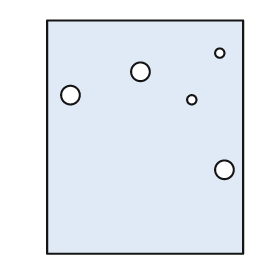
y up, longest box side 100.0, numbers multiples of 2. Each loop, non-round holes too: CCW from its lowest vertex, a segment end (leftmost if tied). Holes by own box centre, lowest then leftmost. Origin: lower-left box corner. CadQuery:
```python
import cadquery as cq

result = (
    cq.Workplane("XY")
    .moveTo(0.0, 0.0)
    .lineTo(84.0, 0.0)
    .lineTo(84.0, 100.0)
    .lineTo(0.0, 100.0)
    .close()
    .moveTo(76.0, 36.0)
    .circle(4.0)
    .moveTo(62.0, 66.0)
    .circle(2.0)
    .moveTo(10.0, 68.0)
    .circle(4.0)
    .moveTo(40.0, 78.0)
    .circle(4.0)
    .moveTo(74.0, 86.0)
    .circle(2.0)
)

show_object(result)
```